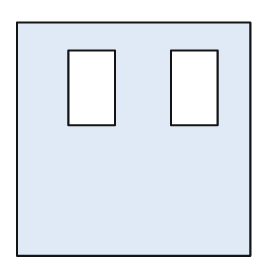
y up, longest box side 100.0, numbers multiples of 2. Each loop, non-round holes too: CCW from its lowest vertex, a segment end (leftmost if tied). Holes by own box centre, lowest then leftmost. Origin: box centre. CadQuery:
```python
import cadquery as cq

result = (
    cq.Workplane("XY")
    .moveTo(-50.0, -50.0)
    .lineTo(50.0, -50.0)
    .lineTo(50.0, 50.0)
    .lineTo(-50.0, 50.0)
    .close()
    .moveTo(-28.0, 6.0)
    .lineTo(-8.0, 6.0)
    .lineTo(-8.0, 38.0)
    .lineTo(-28.0, 38.0)
    .close()
    .moveTo(16.0, 6.0)
    .lineTo(36.0, 6.0)
    .lineTo(36.0, 38.0)
    .lineTo(16.0, 38.0)
    .close()
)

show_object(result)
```